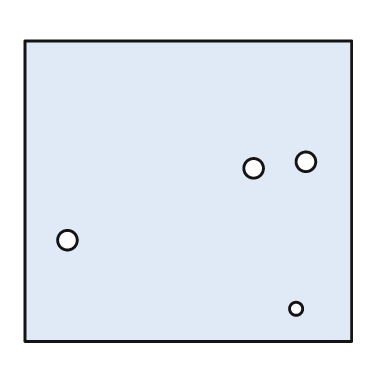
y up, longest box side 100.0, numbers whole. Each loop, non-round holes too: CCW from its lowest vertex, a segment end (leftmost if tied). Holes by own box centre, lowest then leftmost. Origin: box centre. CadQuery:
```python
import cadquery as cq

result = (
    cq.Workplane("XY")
    .moveTo(-50.0, -46.0)
    .lineTo(50.0, -46.0)
    .lineTo(50.0, 46.0)
    .lineTo(-50.0, 46.0)
    .close()
    .moveTo(33.0, -36.0)
    .circle(2.0)
    .moveTo(-37.0, -15.0)
    .circle(3.0)
    .moveTo(20.0, 7.0)
    .circle(3.0)
    .moveTo(36.0, 9.0)
    .circle(3.0)
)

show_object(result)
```